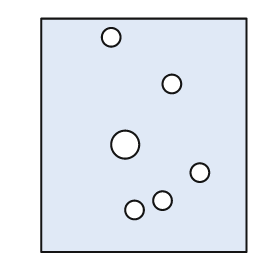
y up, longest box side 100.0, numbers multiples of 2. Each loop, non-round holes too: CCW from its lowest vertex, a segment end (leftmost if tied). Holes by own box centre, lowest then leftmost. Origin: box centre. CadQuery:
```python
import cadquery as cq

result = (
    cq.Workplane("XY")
    .moveTo(-44.0, -50.0)
    .lineTo(44.0, -50.0)
    .lineTo(44.0, 50.0)
    .lineTo(-44.0, 50.0)
    .close()
    .moveTo(-4.0, -32.0)
    .circle(4.0)
    .moveTo(8.0, -28.0)
    .circle(4.0)
    .moveTo(24.0, -16.0)
    .circle(4.0)
    .moveTo(-8.0, -4.0)
    .circle(6.0)
    .moveTo(12.0, 22.0)
    .circle(4.0)
    .moveTo(-14.0, 42.0)
    .circle(4.0)
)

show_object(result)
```